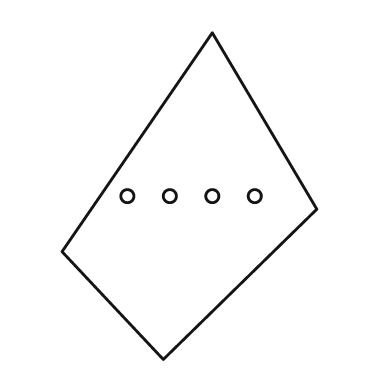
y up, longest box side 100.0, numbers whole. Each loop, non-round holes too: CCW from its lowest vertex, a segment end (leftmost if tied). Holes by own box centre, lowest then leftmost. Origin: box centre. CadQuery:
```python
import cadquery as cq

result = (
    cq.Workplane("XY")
    .moveTo(-8.0, -50.0)
    .lineTo(39.0, -4.0)
    .lineTo(7.0, 50.0)
    .lineTo(-39.0, -17.0)
    .close()
    .moveTo(-19.0, 0.0)
    .circle(2.0)
    .moveTo(-6.0, 0.0)
    .circle(2.0)
    .moveTo(7.0, 0.0)
    .circle(2.0)
    .moveTo(20.0, 0.0)
    .circle(2.0)
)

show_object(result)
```